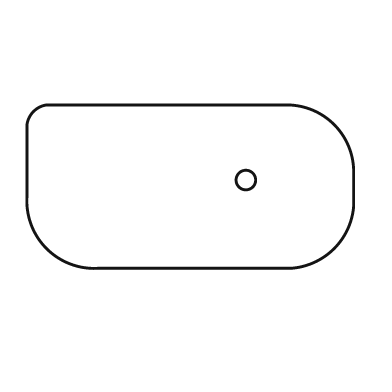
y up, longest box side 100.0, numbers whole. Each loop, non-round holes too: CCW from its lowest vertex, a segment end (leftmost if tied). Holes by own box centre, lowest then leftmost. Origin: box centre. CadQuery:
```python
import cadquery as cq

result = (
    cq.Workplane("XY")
    .moveTo(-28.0, -25.0)
    .lineTo(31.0, -25.0)
    .threePointArc((44.0, -19.0), (50.0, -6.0))
    .lineTo(50.0, 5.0)
    .threePointArc((44.0, 19.0), (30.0, 25.0))
    .lineTo(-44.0, 25.0)
    .threePointArc((-48.0, 23.0), (-50.0, 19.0))
    .lineTo(-50.0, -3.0)
    .threePointArc((-44.0, -19.0), (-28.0, -25.0))
    .close()
    .moveTo(17.0, 2.0)
    .circle(3.0)
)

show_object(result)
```